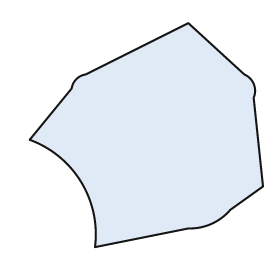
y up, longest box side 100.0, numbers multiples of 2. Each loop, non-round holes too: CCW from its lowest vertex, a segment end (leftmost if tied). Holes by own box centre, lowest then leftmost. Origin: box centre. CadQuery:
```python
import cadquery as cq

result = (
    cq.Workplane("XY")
    .moveTo(-22.0, -48.0)
    .lineTo(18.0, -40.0)
    .threePointArc((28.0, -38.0), (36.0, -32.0))
    .lineTo(50.0, -22.0)
    .lineTo(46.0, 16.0)
    .threePointArc((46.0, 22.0), (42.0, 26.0))
    .lineTo(18.0, 48.0)
    .lineTo(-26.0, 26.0)
    .threePointArc((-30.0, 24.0), (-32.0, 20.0))
    .lineTo(-50.0, -2.0)
    .threePointArc((-28.0, -20.0), (-22.0, -48.0))
    .close()
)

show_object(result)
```